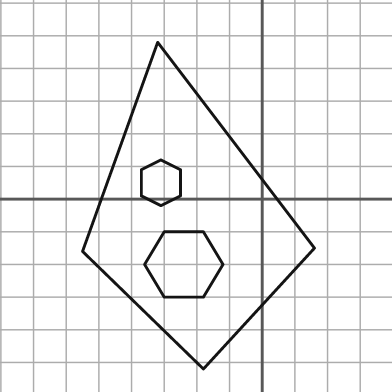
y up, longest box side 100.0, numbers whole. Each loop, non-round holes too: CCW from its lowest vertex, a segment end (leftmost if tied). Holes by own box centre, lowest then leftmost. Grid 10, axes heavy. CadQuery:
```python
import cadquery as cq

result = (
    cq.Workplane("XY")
    .moveTo(-18.0, -52.0)
    .lineTo(16.0, -15.0)
    .lineTo(-32.0, 48.0)
    .lineTo(-55.0, -16.0)
    .close()
    .moveTo(-30.0, -30.0)
    .lineTo(-18.0, -30.0)
    .lineTo(-12.0, -20.0)
    .lineTo(-18.0, -10.0)
    .lineTo(-30.0, -10.0)
    .lineTo(-36.0, -20.0)
    .close()
    .moveTo(-31.0, -2.0)
    .lineTo(-25.0, 1.0)
    .lineTo(-25.0, 9.0)
    .lineTo(-31.0, 12.0)
    .lineTo(-37.0, 9.0)
    .lineTo(-37.0, 1.0)
    .close()
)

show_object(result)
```